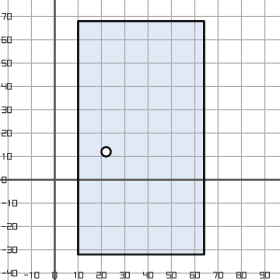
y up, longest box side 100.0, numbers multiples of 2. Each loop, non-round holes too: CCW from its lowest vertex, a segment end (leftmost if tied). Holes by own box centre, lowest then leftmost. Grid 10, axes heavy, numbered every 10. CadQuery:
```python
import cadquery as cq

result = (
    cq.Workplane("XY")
    .moveTo(10.0, -32.0)
    .lineTo(64.0, -32.0)
    .lineTo(64.0, 68.0)
    .lineTo(10.0, 68.0)
    .close()
    .moveTo(22.0, 12.0)
    .circle(2.0)
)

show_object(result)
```